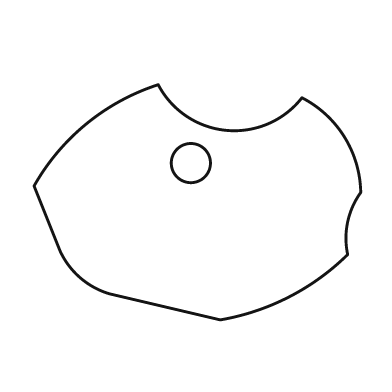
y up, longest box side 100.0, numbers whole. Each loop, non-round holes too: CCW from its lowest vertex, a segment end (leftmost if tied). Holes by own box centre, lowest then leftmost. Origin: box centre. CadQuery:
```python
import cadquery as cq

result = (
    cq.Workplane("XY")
    .moveTo(7.0, -36.0)
    .threePointArc((28.0, -29.0), (46.0, -16.0))
    .threePointArc((46.0, -6.0), (50.0, 3.0))
    .threePointArc((45.0, 20.0), (32.0, 32.0))
    .threePointArc((9.0, 22.0), (-12.0, 36.0))
    .threePointArc((-34.0, 24.0), (-50.0, 5.0))
    .lineTo(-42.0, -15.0)
    .threePointArc((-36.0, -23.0), (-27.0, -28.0))
    .close()
    .moveTo(-2.0, 12.0)
    .circle(6.0)
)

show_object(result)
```